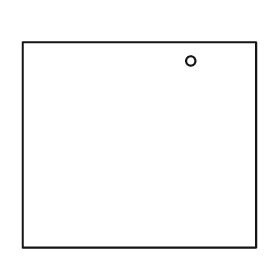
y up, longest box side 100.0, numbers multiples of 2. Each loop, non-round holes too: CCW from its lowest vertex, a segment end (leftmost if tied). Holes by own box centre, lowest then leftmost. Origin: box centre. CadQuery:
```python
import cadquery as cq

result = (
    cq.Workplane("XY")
    .moveTo(-50.0, -44.0)
    .lineTo(50.0, -44.0)
    .lineTo(50.0, 44.0)
    .lineTo(-50.0, 44.0)
    .close()
    .moveTo(22.0, 36.0)
    .circle(2.0)
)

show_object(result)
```